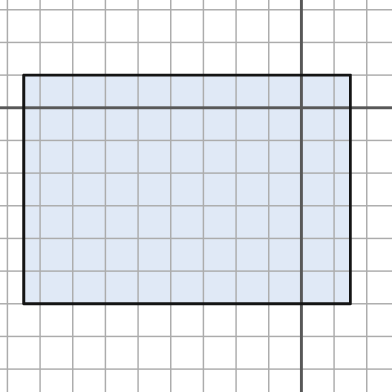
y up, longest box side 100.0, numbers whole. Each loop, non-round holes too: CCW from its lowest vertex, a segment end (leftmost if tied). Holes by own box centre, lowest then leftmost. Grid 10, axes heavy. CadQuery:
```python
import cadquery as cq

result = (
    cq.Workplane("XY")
    .moveTo(-85.0, -60.0)
    .lineTo(15.0, -60.0)
    .lineTo(15.0, 10.0)
    .lineTo(-85.0, 10.0)
    .close()
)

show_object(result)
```